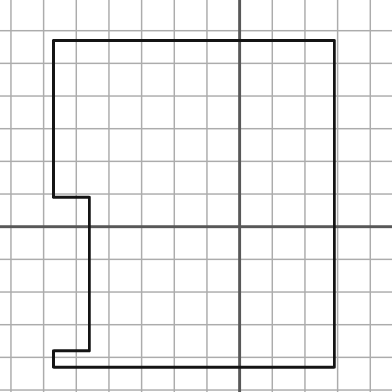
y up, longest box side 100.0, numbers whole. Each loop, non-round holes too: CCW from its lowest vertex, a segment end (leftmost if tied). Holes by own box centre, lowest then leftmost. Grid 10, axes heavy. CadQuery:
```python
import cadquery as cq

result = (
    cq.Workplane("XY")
    .moveTo(-57.0, -43.0)
    .lineTo(29.0, -43.0)
    .lineTo(29.0, 57.0)
    .lineTo(-57.0, 57.0)
    .lineTo(-57.0, 9.0)
    .lineTo(-46.0, 9.0)
    .lineTo(-46.0, -38.0)
    .lineTo(-57.0, -38.0)
    .close()
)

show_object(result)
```